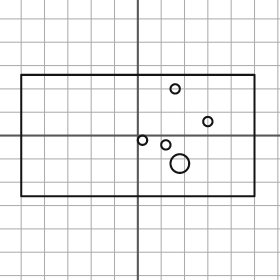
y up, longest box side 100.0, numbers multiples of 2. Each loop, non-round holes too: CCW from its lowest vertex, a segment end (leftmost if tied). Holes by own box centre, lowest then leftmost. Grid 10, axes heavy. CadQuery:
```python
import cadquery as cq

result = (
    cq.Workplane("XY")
    .moveTo(-50.0, -26.0)
    .lineTo(50.0, -26.0)
    .lineTo(50.0, 26.0)
    .lineTo(-50.0, 26.0)
    .close()
    .moveTo(18.0, -12.0)
    .circle(4.0)
    .moveTo(12.0, -4.0)
    .circle(2.0)
    .moveTo(2.0, -2.0)
    .circle(2.0)
    .moveTo(30.0, 6.0)
    .circle(2.0)
    .moveTo(16.0, 20.0)
    .circle(2.0)
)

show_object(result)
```